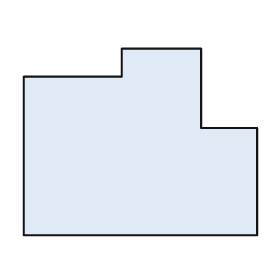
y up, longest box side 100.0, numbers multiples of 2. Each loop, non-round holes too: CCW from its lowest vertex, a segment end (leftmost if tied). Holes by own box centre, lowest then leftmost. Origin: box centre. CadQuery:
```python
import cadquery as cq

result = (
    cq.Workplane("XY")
    .moveTo(-50.0, -40.0)
    .lineTo(50.0, -40.0)
    .lineTo(50.0, 6.0)
    .lineTo(26.0, 6.0)
    .lineTo(26.0, 40.0)
    .lineTo(-8.0, 40.0)
    .lineTo(-8.0, 28.0)
    .lineTo(-50.0, 28.0)
    .close()
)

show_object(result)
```